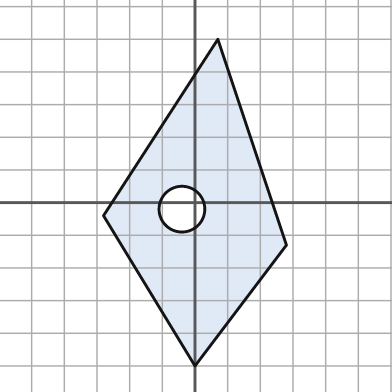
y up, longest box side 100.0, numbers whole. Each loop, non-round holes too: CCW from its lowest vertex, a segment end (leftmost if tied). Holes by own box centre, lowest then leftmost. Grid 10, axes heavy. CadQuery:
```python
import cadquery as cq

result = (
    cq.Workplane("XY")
    .moveTo(0.0, -50.0)
    .lineTo(28.0, -13.0)
    .lineTo(7.0, 50.0)
    .lineTo(-28.0, -4.0)
    .close()
    .moveTo(-4.0, -2.0)
    .circle(7.0)
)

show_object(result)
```